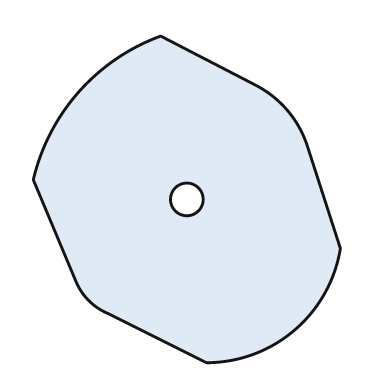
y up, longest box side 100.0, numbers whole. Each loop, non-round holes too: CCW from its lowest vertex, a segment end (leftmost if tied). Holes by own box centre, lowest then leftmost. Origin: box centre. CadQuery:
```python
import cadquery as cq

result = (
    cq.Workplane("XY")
    .moveTo(6.0, -50.0)
    .threePointArc((33.0, -40.0), (47.0, -15.0))
    .lineTo(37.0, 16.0)
    .threePointArc((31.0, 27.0), (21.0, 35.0))
    .lineTo(-8.0, 50.0)
    .threePointArc((-33.0, 33.0), (-47.0, 6.0))
    .lineTo(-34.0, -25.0)
    .threePointArc((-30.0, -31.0), (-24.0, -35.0))
    .close()
    .moveTo(0.0, 0.0)
    .circle(5.0)
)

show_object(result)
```